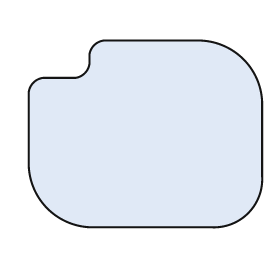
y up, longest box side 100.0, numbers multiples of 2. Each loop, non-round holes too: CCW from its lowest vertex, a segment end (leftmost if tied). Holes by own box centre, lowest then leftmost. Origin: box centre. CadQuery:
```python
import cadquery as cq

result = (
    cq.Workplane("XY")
    .moveTo(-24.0, -40.0)
    .lineTo(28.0, -40.0)
    .threePointArc((44.0, -34.0), (50.0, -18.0))
    .lineTo(50.0, 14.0)
    .threePointArc((42.0, 32.0), (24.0, 40.0))
    .lineTo(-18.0, 40.0)
    .threePointArc((-22.0, 38.0), (-24.0, 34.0))
    .lineTo(-24.0, 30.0)
    .threePointArc((-26.0, 26.0), (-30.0, 24.0))
    .lineTo(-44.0, 24.0)
    .threePointArc((-48.0, 22.0), (-50.0, 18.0))
    .lineTo(-50.0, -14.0)
    .threePointArc((-42.0, -32.0), (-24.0, -40.0))
    .close()
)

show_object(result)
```